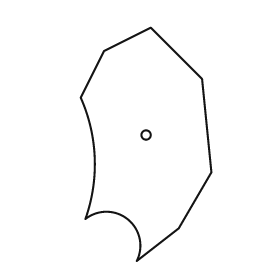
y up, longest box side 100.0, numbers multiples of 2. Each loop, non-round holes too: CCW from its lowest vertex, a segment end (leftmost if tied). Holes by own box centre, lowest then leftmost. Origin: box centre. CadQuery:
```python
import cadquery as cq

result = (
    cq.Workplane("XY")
    .moveTo(-4.0, -50.0)
    .lineTo(14.0, -36.0)
    .lineTo(28.0, -12.0)
    .lineTo(24.0, 28.0)
    .lineTo(2.0, 50.0)
    .lineTo(-18.0, 40.0)
    .lineTo(-28.0, 20.0)
    .threePointArc((-22.0, -6.0), (-26.0, -32.0))
    .threePointArc((-8.0, -32.0), (-4.0, -50.0))
    .close()
    .moveTo(0.0, 4.0)
    .circle(2.0)
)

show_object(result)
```